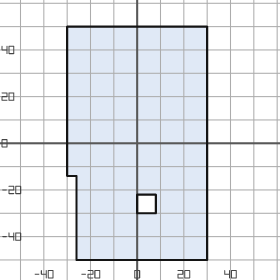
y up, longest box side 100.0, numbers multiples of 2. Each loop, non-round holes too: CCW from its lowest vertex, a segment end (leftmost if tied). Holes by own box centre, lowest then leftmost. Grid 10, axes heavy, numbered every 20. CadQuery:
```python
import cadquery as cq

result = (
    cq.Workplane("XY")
    .moveTo(-26.0, -50.0)
    .lineTo(30.0, -50.0)
    .lineTo(30.0, 50.0)
    .lineTo(-30.0, 50.0)
    .lineTo(-30.0, -14.0)
    .lineTo(-26.0, -14.0)
    .close()
    .moveTo(0.0, -30.0)
    .lineTo(8.0, -30.0)
    .lineTo(8.0, -22.0)
    .lineTo(0.0, -22.0)
    .close()
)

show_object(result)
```